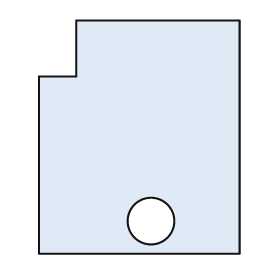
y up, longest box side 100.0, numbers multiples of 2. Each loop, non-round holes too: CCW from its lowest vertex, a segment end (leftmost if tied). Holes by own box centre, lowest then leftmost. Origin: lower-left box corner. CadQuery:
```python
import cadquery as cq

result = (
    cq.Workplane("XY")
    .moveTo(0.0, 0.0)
    .lineTo(86.0, 0.0)
    .lineTo(86.0, 100.0)
    .lineTo(16.0, 100.0)
    .lineTo(16.0, 76.0)
    .lineTo(0.0, 76.0)
    .close()
    .moveTo(48.0, 14.0)
    .circle(10.0)
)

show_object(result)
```